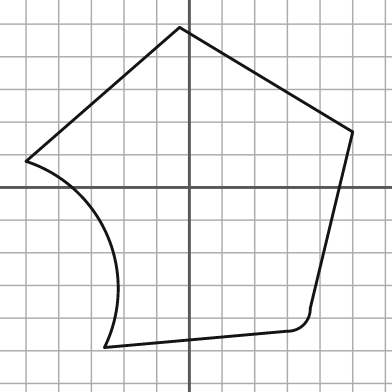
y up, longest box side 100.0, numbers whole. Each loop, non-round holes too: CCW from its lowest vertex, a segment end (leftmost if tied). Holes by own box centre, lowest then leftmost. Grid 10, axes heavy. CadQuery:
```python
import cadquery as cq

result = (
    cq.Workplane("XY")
    .moveTo(-26.0, -49.0)
    .lineTo(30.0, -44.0)
    .threePointArc((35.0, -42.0), (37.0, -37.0))
    .lineTo(50.0, 17.0)
    .lineTo(-3.0, 49.0)
    .lineTo(-50.0, 8.0)
    .threePointArc((-25.0, -15.0), (-26.0, -49.0))
    .close()
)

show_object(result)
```